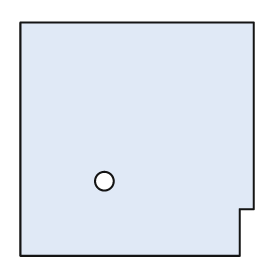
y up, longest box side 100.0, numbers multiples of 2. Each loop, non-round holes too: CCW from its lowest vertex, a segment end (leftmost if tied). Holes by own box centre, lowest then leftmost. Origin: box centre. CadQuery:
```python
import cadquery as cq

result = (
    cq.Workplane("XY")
    .moveTo(-50.0, -50.0)
    .lineTo(44.0, -50.0)
    .lineTo(44.0, -30.0)
    .lineTo(50.0, -30.0)
    .lineTo(50.0, 50.0)
    .lineTo(-50.0, 50.0)
    .close()
    .moveTo(-14.0, -18.0)
    .circle(4.0)
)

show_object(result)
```